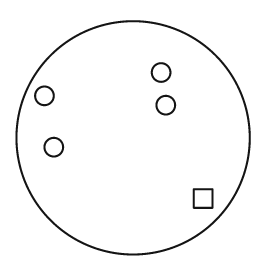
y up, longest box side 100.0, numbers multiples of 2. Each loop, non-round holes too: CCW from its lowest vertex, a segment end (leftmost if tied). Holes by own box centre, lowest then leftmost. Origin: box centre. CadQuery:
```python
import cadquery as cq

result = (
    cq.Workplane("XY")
    .moveTo(0.0, 0.0)
    .circle(50.0)
    .moveTo(26.0, -30.0)
    .lineTo(34.0, -30.0)
    .lineTo(34.0, -22.0)
    .lineTo(26.0, -22.0)
    .close()
    .moveTo(-34.0, -4.0)
    .circle(4.0)
    .moveTo(14.0, 14.0)
    .circle(4.0)
    .moveTo(-38.0, 18.0)
    .circle(4.0)
    .moveTo(12.0, 28.0)
    .circle(4.0)
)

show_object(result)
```